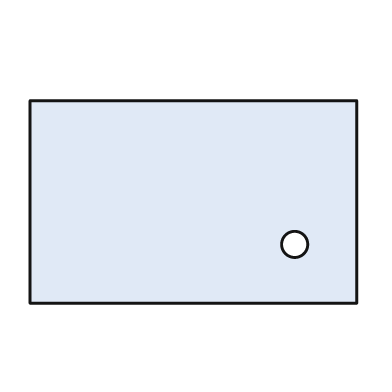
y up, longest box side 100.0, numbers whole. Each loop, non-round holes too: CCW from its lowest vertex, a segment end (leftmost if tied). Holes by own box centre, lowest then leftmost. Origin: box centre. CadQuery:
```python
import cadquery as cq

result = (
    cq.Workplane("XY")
    .moveTo(-50.0, -31.0)
    .lineTo(50.0, -31.0)
    .lineTo(50.0, 31.0)
    .lineTo(-50.0, 31.0)
    .close()
    .moveTo(31.0, -13.0)
    .circle(4.0)
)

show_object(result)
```